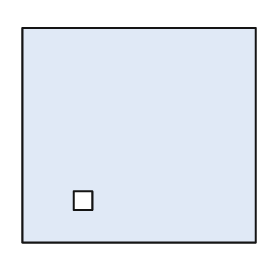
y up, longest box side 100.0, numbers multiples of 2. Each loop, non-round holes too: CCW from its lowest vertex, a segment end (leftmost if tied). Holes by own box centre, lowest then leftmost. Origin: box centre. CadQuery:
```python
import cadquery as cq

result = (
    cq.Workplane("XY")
    .moveTo(-50.0, -46.0)
    .lineTo(50.0, -46.0)
    .lineTo(50.0, 46.0)
    .lineTo(-50.0, 46.0)
    .close()
    .moveTo(-28.0, -32.0)
    .lineTo(-20.0, -32.0)
    .lineTo(-20.0, -24.0)
    .lineTo(-28.0, -24.0)
    .close()
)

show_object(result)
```